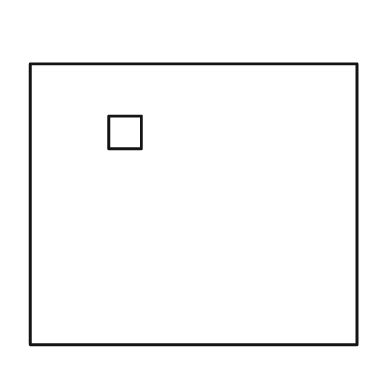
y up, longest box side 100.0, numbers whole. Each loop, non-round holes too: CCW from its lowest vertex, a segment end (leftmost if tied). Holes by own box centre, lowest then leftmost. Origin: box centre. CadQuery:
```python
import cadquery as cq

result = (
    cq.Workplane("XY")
    .moveTo(-50.0, -43.0)
    .lineTo(50.0, -43.0)
    .lineTo(50.0, 43.0)
    .lineTo(-50.0, 43.0)
    .close()
    .moveTo(-26.0, 17.0)
    .lineTo(-16.0, 17.0)
    .lineTo(-16.0, 27.0)
    .lineTo(-26.0, 27.0)
    .close()
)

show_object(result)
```